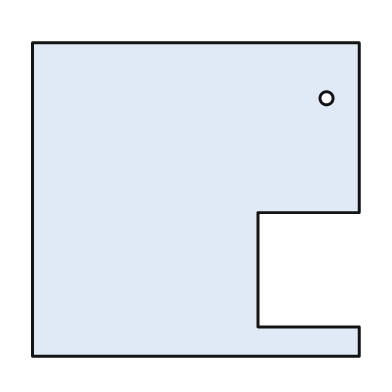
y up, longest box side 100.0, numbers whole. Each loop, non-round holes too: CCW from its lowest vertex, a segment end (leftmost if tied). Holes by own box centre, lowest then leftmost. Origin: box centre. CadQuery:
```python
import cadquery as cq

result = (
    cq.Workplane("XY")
    .moveTo(-50.0, -48.0)
    .lineTo(50.0, -48.0)
    .lineTo(50.0, -39.0)
    .lineTo(19.0, -39.0)
    .lineTo(19.0, -4.0)
    .lineTo(50.0, -4.0)
    .lineTo(50.0, 48.0)
    .lineTo(-50.0, 48.0)
    .close()
    .moveTo(40.0, 31.0)
    .circle(2.0)
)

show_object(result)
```